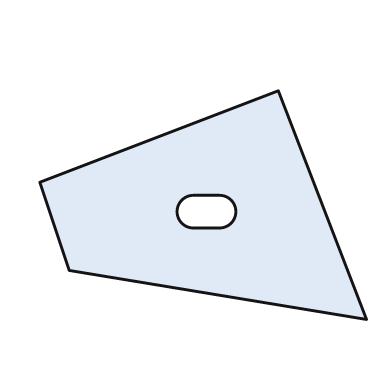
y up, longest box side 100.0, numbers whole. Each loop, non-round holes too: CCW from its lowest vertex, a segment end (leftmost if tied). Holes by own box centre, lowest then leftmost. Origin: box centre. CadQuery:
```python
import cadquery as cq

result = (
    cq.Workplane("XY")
    .moveTo(50.0, -35.0)
    .lineTo(23.0, 35.0)
    .lineTo(-50.0, 7.0)
    .lineTo(-41.0, -20.0)
    .close()
    .moveTo(-3.0, -7.0)
    .lineTo(5.0, -7.0)
    .threePointArc((10.0, -2.0), (5.0, 3.0))
    .lineTo(-3.0, 3.0)
    .threePointArc((-8.0, -2.0), (-3.0, -7.0))
    .close()
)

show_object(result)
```